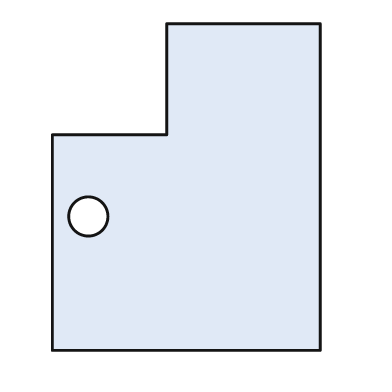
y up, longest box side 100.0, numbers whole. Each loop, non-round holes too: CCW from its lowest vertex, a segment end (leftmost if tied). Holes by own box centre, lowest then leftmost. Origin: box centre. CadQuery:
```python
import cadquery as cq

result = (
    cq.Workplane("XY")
    .moveTo(-41.0, -50.0)
    .lineTo(41.0, -50.0)
    .lineTo(41.0, 50.0)
    .lineTo(-6.0, 50.0)
    .lineTo(-6.0, 16.0)
    .lineTo(-41.0, 16.0)
    .close()
    .moveTo(-30.0, -9.0)
    .circle(6.0)
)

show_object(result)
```